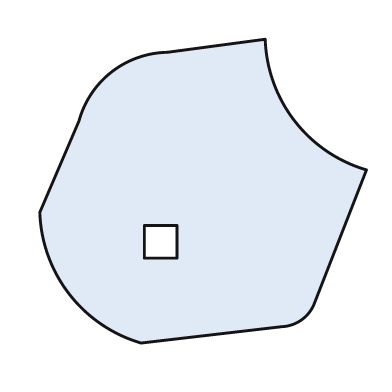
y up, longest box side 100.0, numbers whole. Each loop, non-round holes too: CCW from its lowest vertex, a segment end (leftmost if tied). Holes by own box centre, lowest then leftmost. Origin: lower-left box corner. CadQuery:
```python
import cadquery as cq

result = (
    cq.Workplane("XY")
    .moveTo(31.0, 0.0)
    .lineTo(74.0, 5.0)
    .threePointArc((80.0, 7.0), (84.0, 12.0))
    .lineTo(100.0, 53.0)
    .threePointArc((78.0, 68.0), (69.0, 93.0))
    .lineTo(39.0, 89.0)
    .threePointArc((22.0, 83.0), (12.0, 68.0))
    .lineTo(0.0, 40.0)
    .threePointArc((9.0, 15.0), (31.0, 0.0))
    .close()
    .moveTo(32.0, 26.0)
    .lineTo(42.0, 26.0)
    .lineTo(42.0, 36.0)
    .lineTo(32.0, 36.0)
    .close()
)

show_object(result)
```